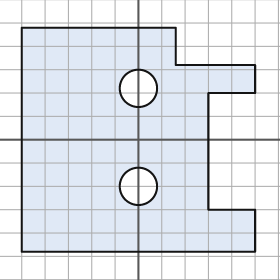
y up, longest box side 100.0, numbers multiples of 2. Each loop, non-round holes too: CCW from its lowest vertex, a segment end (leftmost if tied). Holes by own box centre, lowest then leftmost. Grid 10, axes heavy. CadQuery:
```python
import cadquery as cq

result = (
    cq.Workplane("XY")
    .moveTo(-50.0, -48.0)
    .lineTo(50.0, -48.0)
    .lineTo(50.0, -30.0)
    .lineTo(30.0, -30.0)
    .lineTo(30.0, 20.0)
    .lineTo(50.0, 20.0)
    .lineTo(50.0, 32.0)
    .lineTo(16.0, 32.0)
    .lineTo(16.0, 48.0)
    .lineTo(-50.0, 48.0)
    .close()
    .moveTo(0.0, -20.0)
    .circle(8.0)
    .moveTo(0.0, 22.0)
    .circle(8.0)
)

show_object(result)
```